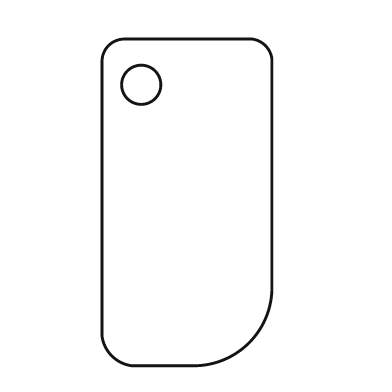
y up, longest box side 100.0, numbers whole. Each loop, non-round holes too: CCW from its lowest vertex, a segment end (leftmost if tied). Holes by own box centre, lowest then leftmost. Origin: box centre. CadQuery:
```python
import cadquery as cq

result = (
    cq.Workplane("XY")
    .moveTo(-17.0, -50.0)
    .lineTo(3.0, -50.0)
    .threePointArc((19.0, -43.0), (26.0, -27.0))
    .lineTo(26.0, 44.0)
    .threePointArc((24.0, 48.0), (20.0, 50.0))
    .lineTo(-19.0, 50.0)
    .threePointArc((-24.0, 48.0), (-26.0, 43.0))
    .lineTo(-26.0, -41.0)
    .threePointArc((-23.0, -47.0), (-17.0, -50.0))
    .close()
    .moveTo(-14.0, 36.0)
    .circle(6.0)
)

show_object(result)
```